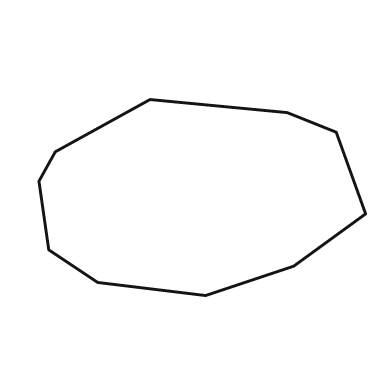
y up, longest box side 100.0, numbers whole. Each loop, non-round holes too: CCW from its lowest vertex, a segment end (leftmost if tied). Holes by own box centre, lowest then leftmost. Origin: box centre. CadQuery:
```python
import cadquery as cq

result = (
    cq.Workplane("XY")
    .moveTo(1.0, -30.0)
    .lineTo(28.0, -21.0)
    .lineTo(50.0, -5.0)
    .lineTo(41.0, 20.0)
    .lineTo(26.0, 26.0)
    .lineTo(-16.0, 30.0)
    .lineTo(-45.0, 14.0)
    .lineTo(-50.0, 5.0)
    .lineTo(-47.0, -16.0)
    .lineTo(-32.0, -26.0)
    .close()
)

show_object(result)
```